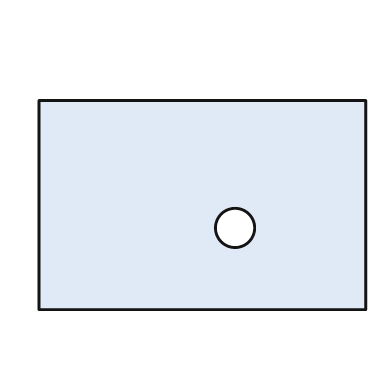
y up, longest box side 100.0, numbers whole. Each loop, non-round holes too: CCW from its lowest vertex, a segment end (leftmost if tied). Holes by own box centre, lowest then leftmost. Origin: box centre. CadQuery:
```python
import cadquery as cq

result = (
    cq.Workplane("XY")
    .moveTo(-50.0, -32.0)
    .lineTo(50.0, -32.0)
    .lineTo(50.0, 32.0)
    .lineTo(-50.0, 32.0)
    .close()
    .moveTo(10.0, -7.0)
    .circle(6.0)
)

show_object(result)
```